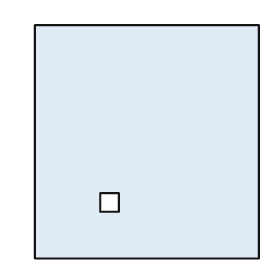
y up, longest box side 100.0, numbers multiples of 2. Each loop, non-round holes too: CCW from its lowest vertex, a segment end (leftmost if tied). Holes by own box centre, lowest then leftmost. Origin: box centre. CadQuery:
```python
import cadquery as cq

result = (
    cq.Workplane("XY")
    .moveTo(-48.0, -50.0)
    .lineTo(48.0, -50.0)
    .lineTo(48.0, 50.0)
    .lineTo(-48.0, 50.0)
    .close()
    .moveTo(-20.0, -30.0)
    .lineTo(-12.0, -30.0)
    .lineTo(-12.0, -22.0)
    .lineTo(-20.0, -22.0)
    .close()
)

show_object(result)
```